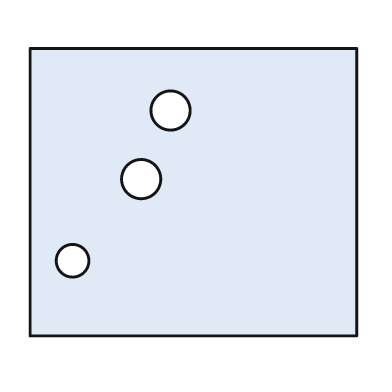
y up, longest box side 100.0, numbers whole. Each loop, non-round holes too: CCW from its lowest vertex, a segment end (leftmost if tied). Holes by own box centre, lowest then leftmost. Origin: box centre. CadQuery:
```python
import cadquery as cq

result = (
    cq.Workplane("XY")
    .moveTo(-50.0, -44.0)
    .lineTo(50.0, -44.0)
    .lineTo(50.0, 44.0)
    .lineTo(-50.0, 44.0)
    .close()
    .moveTo(-37.0, -21.0)
    .circle(5.0)
    .moveTo(-16.0, 4.0)
    .circle(6.0)
    .moveTo(-7.0, 25.0)
    .circle(6.0)
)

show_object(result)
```